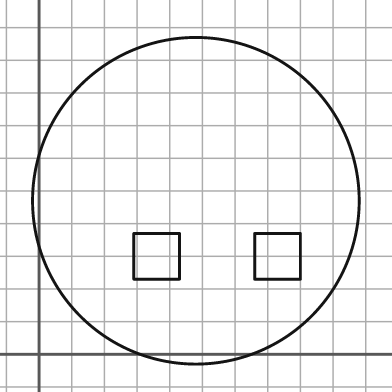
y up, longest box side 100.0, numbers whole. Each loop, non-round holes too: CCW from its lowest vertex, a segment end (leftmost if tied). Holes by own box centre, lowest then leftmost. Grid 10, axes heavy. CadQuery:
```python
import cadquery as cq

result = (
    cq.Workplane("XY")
    .moveTo(48.0, 47.0)
    .circle(50.0)
    .moveTo(29.0, 23.0)
    .lineTo(43.0, 23.0)
    .lineTo(43.0, 37.0)
    .lineTo(29.0, 37.0)
    .close()
    .moveTo(66.0, 23.0)
    .lineTo(80.0, 23.0)
    .lineTo(80.0, 37.0)
    .lineTo(66.0, 37.0)
    .close()
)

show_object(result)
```